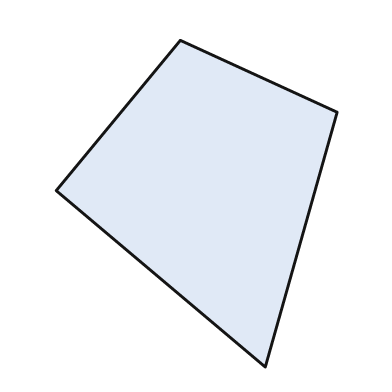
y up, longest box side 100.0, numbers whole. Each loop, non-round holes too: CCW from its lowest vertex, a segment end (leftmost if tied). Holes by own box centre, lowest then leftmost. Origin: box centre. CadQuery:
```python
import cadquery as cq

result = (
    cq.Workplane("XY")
    .moveTo(21.0, -50.0)
    .lineTo(43.0, 28.0)
    .lineTo(-5.0, 50.0)
    .lineTo(-43.0, 4.0)
    .close()
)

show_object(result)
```